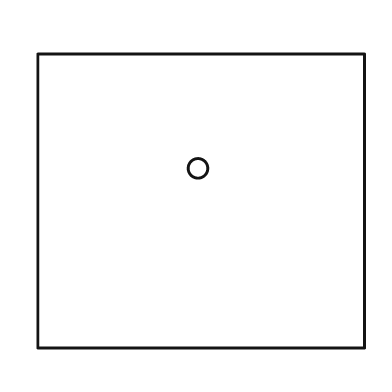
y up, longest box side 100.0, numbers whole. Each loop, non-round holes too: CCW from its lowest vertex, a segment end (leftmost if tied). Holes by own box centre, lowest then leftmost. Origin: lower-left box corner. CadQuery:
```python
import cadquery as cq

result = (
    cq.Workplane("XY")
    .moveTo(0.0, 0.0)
    .lineTo(100.0, 0.0)
    .lineTo(100.0, 90.0)
    .lineTo(0.0, 90.0)
    .close()
    .moveTo(49.0, 55.0)
    .circle(3.0)
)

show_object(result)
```